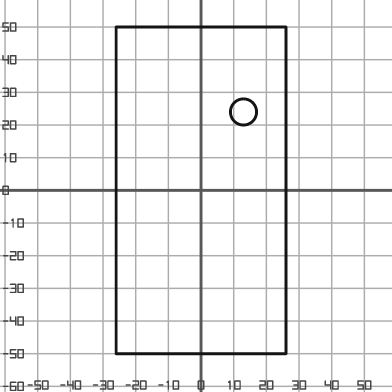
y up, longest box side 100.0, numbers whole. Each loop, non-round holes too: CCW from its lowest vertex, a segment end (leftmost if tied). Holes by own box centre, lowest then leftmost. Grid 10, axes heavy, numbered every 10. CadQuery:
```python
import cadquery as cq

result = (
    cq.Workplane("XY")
    .moveTo(-26.0, -50.0)
    .lineTo(26.0, -50.0)
    .lineTo(26.0, 50.0)
    .lineTo(-26.0, 50.0)
    .close()
    .moveTo(13.0, 24.0)
    .circle(4.0)
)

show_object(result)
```